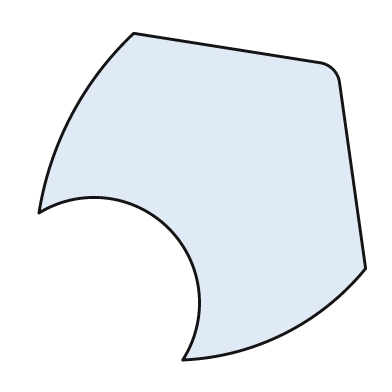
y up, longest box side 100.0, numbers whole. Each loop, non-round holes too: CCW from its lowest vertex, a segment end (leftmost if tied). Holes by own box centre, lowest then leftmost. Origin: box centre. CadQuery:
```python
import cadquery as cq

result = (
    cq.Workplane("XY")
    .moveTo(-6.0, -50.0)
    .threePointArc((25.0, -42.0), (50.0, -22.0))
    .lineTo(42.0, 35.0)
    .threePointArc((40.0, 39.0), (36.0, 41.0))
    .lineTo(-21.0, 50.0)
    .threePointArc((-40.0, 25.0), (-50.0, -5.0))
    .threePointArc((-10.0, -10.0), (-6.0, -50.0))
    .close()
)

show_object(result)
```